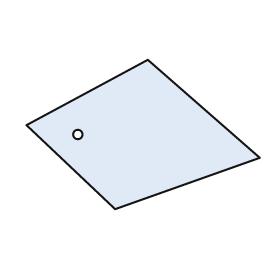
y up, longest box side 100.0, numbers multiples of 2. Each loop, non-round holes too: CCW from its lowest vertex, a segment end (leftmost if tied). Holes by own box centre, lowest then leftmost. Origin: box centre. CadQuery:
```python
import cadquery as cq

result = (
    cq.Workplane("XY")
    .moveTo(-12.0, -32.0)
    .lineTo(50.0, -10.0)
    .lineTo(2.0, 32.0)
    .lineTo(-50.0, 4.0)
    .close()
    .moveTo(-28.0, 0.0)
    .circle(2.0)
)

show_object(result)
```